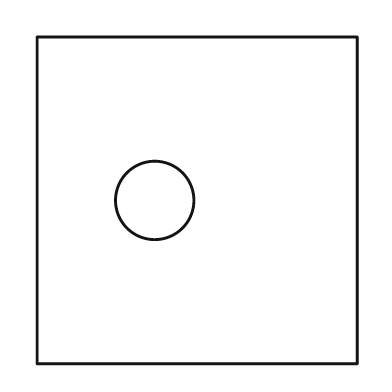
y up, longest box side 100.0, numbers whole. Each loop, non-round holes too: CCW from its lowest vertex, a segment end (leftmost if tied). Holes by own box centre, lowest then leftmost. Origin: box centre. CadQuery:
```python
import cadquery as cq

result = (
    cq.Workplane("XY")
    .moveTo(-49.0, -50.0)
    .lineTo(49.0, -50.0)
    .lineTo(49.0, 50.0)
    .lineTo(-49.0, 50.0)
    .close()
    .moveTo(-13.0, 0.0)
    .circle(12.0)
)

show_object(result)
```